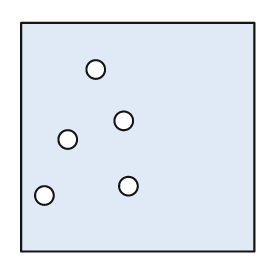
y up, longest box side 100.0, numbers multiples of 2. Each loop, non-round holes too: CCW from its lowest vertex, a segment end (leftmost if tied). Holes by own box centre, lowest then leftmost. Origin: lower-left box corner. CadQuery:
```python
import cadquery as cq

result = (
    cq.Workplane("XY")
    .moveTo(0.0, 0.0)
    .lineTo(100.0, 0.0)
    .lineTo(100.0, 98.0)
    .lineTo(0.0, 98.0)
    .close()
    .moveTo(10.0, 24.0)
    .circle(4.0)
    .moveTo(46.0, 28.0)
    .circle(4.0)
    .moveTo(20.0, 48.0)
    .circle(4.0)
    .moveTo(44.0, 56.0)
    .circle(4.0)
    .moveTo(32.0, 78.0)
    .circle(4.0)
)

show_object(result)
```